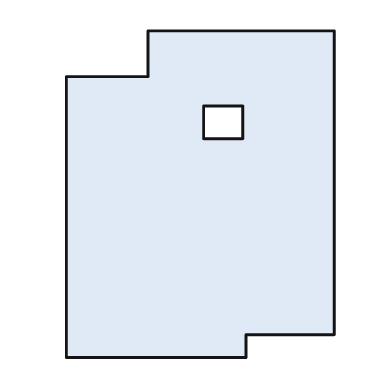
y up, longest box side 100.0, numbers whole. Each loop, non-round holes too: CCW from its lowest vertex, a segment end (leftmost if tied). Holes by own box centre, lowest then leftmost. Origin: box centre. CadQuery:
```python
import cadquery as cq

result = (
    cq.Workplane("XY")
    .moveTo(-41.0, -50.0)
    .lineTo(14.0, -50.0)
    .lineTo(14.0, -43.0)
    .lineTo(41.0, -43.0)
    .lineTo(41.0, 50.0)
    .lineTo(-16.0, 50.0)
    .lineTo(-16.0, 36.0)
    .lineTo(-41.0, 36.0)
    .close()
    .moveTo(1.0, 17.0)
    .lineTo(13.0, 17.0)
    .lineTo(13.0, 27.0)
    .lineTo(1.0, 27.0)
    .close()
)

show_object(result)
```